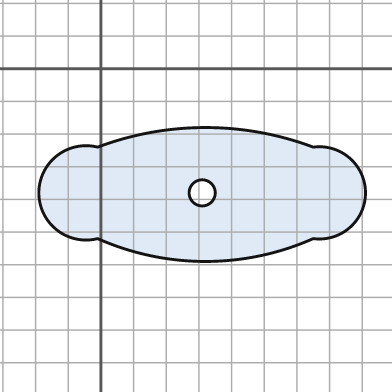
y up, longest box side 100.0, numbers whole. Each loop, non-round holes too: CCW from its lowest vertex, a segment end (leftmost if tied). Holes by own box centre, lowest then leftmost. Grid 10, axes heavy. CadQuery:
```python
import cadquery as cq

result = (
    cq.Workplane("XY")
    .moveTo(-1.0, -52.0)
    .threePointArc((32.0, -59.0), (65.0, -52.0))
    .threePointArc((81.0, -38.0), (65.0, -24.0))
    .threePointArc((32.0, -18.0), (-1.0, -24.0))
    .threePointArc((-19.0, -38.0), (-1.0, -52.0))
    .close()
    .moveTo(31.0, -38.0)
    .circle(4.0)
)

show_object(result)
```